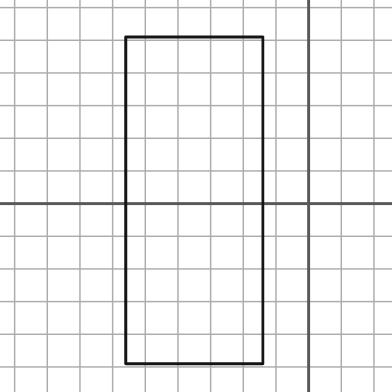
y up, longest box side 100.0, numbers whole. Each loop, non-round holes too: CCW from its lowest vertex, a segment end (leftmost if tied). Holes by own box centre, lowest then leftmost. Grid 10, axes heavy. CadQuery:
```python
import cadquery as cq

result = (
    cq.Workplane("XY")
    .moveTo(-56.0, -49.0)
    .lineTo(-14.0, -49.0)
    .lineTo(-14.0, 51.0)
    .lineTo(-56.0, 51.0)
    .close()
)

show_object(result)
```